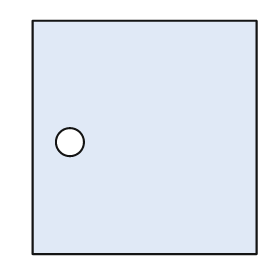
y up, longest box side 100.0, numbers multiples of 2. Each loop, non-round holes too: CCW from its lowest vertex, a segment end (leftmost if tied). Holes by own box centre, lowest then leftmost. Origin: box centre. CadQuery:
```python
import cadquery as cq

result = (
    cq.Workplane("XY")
    .moveTo(-48.0, -50.0)
    .lineTo(48.0, -50.0)
    .lineTo(48.0, 50.0)
    .lineTo(-48.0, 50.0)
    .close()
    .moveTo(-32.0, -2.0)
    .circle(6.0)
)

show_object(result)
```